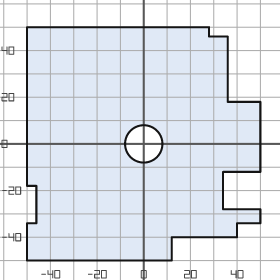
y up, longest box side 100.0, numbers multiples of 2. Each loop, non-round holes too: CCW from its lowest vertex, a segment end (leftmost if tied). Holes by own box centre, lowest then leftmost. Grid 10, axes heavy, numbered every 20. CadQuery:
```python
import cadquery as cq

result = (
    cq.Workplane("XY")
    .moveTo(-50.0, -50.0)
    .lineTo(12.0, -50.0)
    .lineTo(12.0, -40.0)
    .lineTo(40.0, -40.0)
    .lineTo(40.0, -34.0)
    .lineTo(50.0, -34.0)
    .lineTo(50.0, -28.0)
    .lineTo(34.0, -28.0)
    .lineTo(34.0, -12.0)
    .lineTo(50.0, -12.0)
    .lineTo(50.0, 18.0)
    .lineTo(36.0, 18.0)
    .lineTo(36.0, 46.0)
    .lineTo(28.0, 46.0)
    .lineTo(28.0, 50.0)
    .lineTo(-50.0, 50.0)
    .lineTo(-50.0, -18.0)
    .lineTo(-46.0, -18.0)
    .lineTo(-46.0, -34.0)
    .lineTo(-50.0, -34.0)
    .close()
    .moveTo(0.0, 0.0)
    .circle(8.0)
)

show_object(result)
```